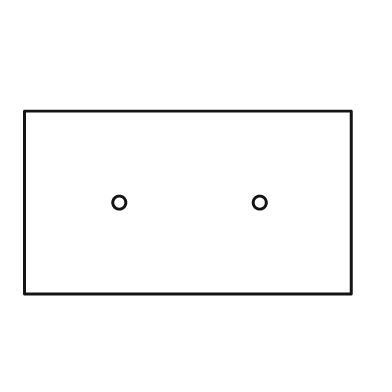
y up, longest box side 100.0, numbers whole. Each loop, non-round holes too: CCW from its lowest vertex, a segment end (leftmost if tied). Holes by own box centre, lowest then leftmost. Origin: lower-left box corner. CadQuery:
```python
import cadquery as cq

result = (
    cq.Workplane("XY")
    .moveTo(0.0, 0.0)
    .lineTo(100.0, 0.0)
    .lineTo(100.0, 56.0)
    .lineTo(0.0, 56.0)
    .close()
    .moveTo(29.0, 28.0)
    .circle(2.0)
    .moveTo(72.0, 28.0)
    .circle(2.0)
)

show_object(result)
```